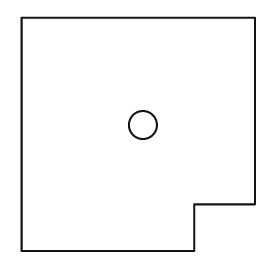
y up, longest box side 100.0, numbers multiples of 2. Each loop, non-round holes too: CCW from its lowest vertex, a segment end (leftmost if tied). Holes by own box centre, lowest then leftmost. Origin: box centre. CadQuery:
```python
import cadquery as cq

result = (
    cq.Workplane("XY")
    .moveTo(-50.0, -50.0)
    .lineTo(24.0, -50.0)
    .lineTo(24.0, -30.0)
    .lineTo(50.0, -30.0)
    .lineTo(50.0, 50.0)
    .lineTo(-50.0, 50.0)
    .close()
    .moveTo(2.0, 4.0)
    .circle(6.0)
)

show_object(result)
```